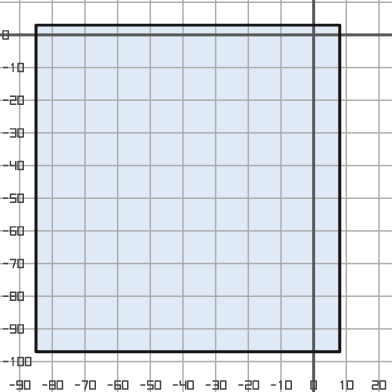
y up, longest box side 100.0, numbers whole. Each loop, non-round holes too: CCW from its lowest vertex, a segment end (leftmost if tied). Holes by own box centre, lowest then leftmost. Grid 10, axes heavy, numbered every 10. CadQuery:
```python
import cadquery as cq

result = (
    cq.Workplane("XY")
    .moveTo(-85.0, -97.0)
    .lineTo(8.0, -97.0)
    .lineTo(8.0, 3.0)
    .lineTo(-85.0, 3.0)
    .close()
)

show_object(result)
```